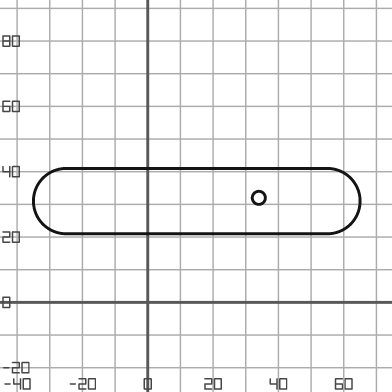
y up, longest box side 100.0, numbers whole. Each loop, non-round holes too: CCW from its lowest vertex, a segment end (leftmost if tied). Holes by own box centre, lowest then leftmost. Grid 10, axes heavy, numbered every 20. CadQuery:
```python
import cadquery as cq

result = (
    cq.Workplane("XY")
    .moveTo(-25.0, 21.0)
    .lineTo(55.0, 21.0)
    .threePointArc((65.0, 31.0), (55.0, 41.0))
    .lineTo(-25.0, 41.0)
    .threePointArc((-35.0, 31.0), (-25.0, 21.0))
    .close()
    .moveTo(34.0, 32.0)
    .circle(2.0)
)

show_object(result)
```